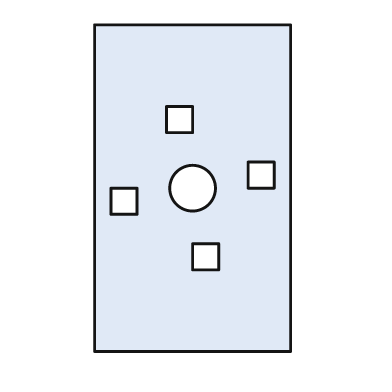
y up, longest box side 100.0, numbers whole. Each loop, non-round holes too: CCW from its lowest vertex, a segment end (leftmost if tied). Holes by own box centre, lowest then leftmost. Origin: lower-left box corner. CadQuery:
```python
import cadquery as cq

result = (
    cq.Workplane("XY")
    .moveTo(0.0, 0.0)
    .lineTo(60.0, 0.0)
    .lineTo(60.0, 100.0)
    .lineTo(0.0, 100.0)
    .close()
    .moveTo(30.0, 25.0)
    .lineTo(38.0, 25.0)
    .lineTo(38.0, 33.0)
    .lineTo(30.0, 33.0)
    .close()
    .moveTo(5.0, 42.0)
    .lineTo(13.0, 42.0)
    .lineTo(13.0, 50.0)
    .lineTo(5.0, 50.0)
    .close()
    .moveTo(30.0, 50.0)
    .circle(7.0)
    .moveTo(47.0, 50.0)
    .lineTo(55.0, 50.0)
    .lineTo(55.0, 58.0)
    .lineTo(47.0, 58.0)
    .close()
    .moveTo(22.0, 67.0)
    .lineTo(30.0, 67.0)
    .lineTo(30.0, 75.0)
    .lineTo(22.0, 75.0)
    .close()
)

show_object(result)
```